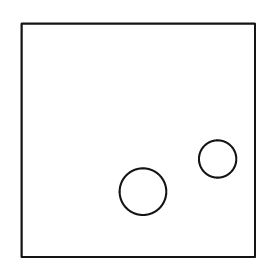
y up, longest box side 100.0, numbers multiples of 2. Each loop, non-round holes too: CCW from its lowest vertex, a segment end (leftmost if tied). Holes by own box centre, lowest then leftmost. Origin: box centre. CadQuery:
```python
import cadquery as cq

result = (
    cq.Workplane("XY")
    .moveTo(-50.0, -50.0)
    .lineTo(50.0, -50.0)
    .lineTo(50.0, 50.0)
    .lineTo(-50.0, 50.0)
    .close()
    .moveTo(2.0, -22.0)
    .circle(10.0)
    .moveTo(34.0, -8.0)
    .circle(8.0)
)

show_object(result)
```